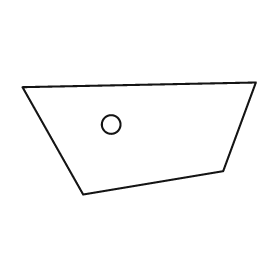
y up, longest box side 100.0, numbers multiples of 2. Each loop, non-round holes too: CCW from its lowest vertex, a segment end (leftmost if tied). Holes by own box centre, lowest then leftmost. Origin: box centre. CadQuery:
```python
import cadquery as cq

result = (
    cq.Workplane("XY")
    .moveTo(-24.0, -24.0)
    .lineTo(36.0, -14.0)
    .lineTo(50.0, 24.0)
    .lineTo(-50.0, 22.0)
    .close()
    .moveTo(-12.0, 6.0)
    .circle(4.0)
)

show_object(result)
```